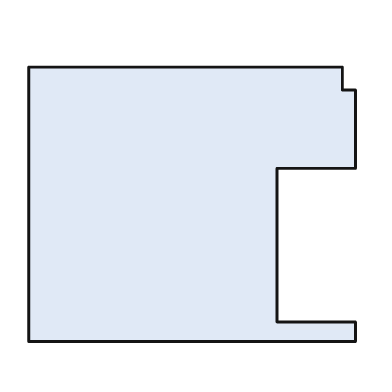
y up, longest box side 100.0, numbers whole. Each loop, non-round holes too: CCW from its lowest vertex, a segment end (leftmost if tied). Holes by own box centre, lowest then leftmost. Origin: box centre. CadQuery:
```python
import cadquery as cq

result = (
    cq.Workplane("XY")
    .moveTo(-50.0, -42.0)
    .lineTo(50.0, -42.0)
    .lineTo(50.0, -36.0)
    .lineTo(26.0, -36.0)
    .lineTo(26.0, 11.0)
    .lineTo(50.0, 11.0)
    .lineTo(50.0, 35.0)
    .lineTo(46.0, 35.0)
    .lineTo(46.0, 42.0)
    .lineTo(-50.0, 42.0)
    .close()
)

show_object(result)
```